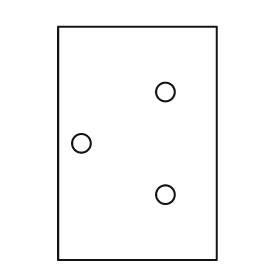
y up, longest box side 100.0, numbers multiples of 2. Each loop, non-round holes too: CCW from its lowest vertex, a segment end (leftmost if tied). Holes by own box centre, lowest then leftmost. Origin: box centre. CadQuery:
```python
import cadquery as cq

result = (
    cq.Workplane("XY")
    .moveTo(-34.0, -50.0)
    .lineTo(34.0, -50.0)
    .lineTo(34.0, 50.0)
    .lineTo(-34.0, 50.0)
    .close()
    .moveTo(12.0, -22.0)
    .circle(4.0)
    .moveTo(-24.0, 0.0)
    .circle(4.0)
    .moveTo(12.0, 22.0)
    .circle(4.0)
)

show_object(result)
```